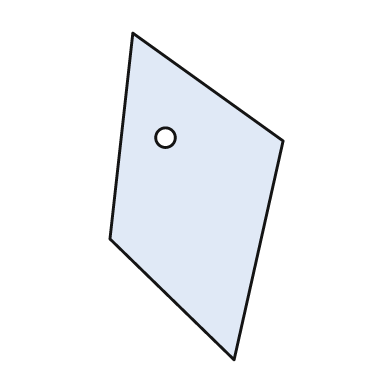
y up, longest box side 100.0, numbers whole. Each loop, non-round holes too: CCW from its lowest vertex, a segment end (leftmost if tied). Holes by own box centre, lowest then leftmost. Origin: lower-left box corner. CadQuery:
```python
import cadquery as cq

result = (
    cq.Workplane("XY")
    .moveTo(38.0, 0.0)
    .lineTo(53.0, 67.0)
    .lineTo(7.0, 100.0)
    .lineTo(0.0, 37.0)
    .close()
    .moveTo(17.0, 68.0)
    .circle(3.0)
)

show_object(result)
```